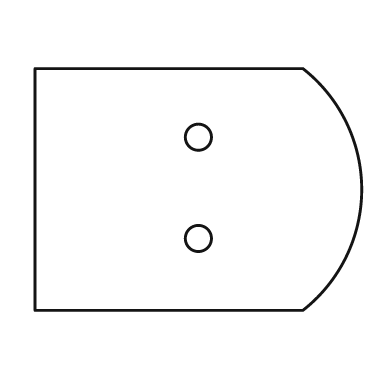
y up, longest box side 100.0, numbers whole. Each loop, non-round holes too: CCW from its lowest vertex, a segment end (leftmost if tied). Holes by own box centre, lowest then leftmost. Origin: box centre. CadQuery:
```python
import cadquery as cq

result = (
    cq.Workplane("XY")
    .moveTo(-50.0, -37.0)
    .lineTo(32.0, -37.0)
    .threePointArc((50.0, 0.0), (32.0, 37.0))
    .lineTo(-50.0, 37.0)
    .close()
    .moveTo(0.0, -15.0)
    .circle(4.0)
    .moveTo(0.0, 16.0)
    .circle(4.0)
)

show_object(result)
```